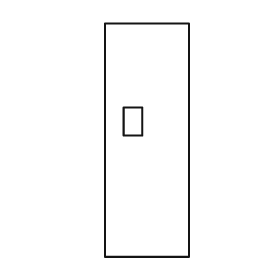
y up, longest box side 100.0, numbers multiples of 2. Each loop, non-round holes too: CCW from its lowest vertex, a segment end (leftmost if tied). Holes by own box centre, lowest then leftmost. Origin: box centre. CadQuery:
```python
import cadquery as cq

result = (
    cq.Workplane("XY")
    .moveTo(-18.0, -50.0)
    .lineTo(18.0, -50.0)
    .lineTo(18.0, 50.0)
    .lineTo(-18.0, 50.0)
    .close()
    .moveTo(-10.0, 2.0)
    .lineTo(-2.0, 2.0)
    .lineTo(-2.0, 14.0)
    .lineTo(-10.0, 14.0)
    .close()
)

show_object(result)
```